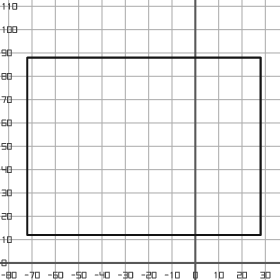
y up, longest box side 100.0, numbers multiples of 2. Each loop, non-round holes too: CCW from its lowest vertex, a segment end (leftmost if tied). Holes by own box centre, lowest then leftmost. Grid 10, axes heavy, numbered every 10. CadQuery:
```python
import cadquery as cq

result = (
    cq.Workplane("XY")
    .moveTo(-72.0, 12.0)
    .lineTo(28.0, 12.0)
    .lineTo(28.0, 88.0)
    .lineTo(-72.0, 88.0)
    .close()
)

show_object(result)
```